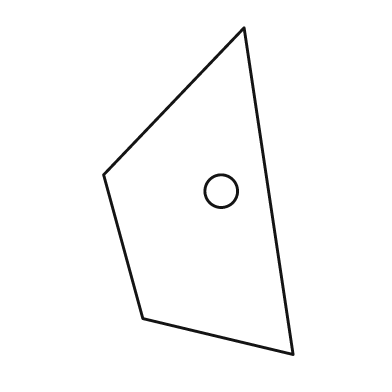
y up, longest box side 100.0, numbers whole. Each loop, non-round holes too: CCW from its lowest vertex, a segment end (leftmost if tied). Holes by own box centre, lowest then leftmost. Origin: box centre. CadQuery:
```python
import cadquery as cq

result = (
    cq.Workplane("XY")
    .moveTo(29.0, -50.0)
    .lineTo(14.0, 50.0)
    .lineTo(-29.0, 5.0)
    .lineTo(-17.0, -39.0)
    .close()
    .moveTo(7.0, 0.0)
    .circle(5.0)
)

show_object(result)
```